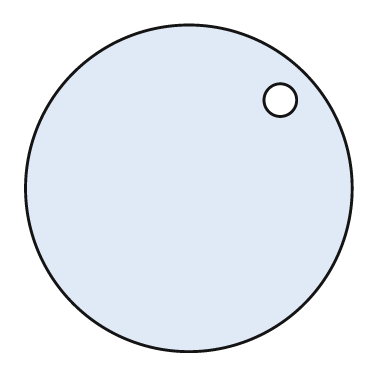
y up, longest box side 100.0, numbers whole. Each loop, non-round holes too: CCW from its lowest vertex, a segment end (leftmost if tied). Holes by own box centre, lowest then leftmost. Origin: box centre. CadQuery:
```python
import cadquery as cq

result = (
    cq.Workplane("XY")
    .moveTo(0.0, 0.0)
    .circle(50.0)
    .moveTo(28.0, 27.0)
    .circle(5.0)
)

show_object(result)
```